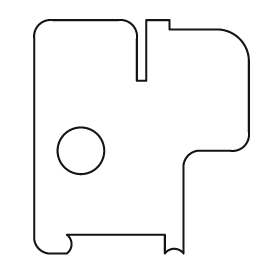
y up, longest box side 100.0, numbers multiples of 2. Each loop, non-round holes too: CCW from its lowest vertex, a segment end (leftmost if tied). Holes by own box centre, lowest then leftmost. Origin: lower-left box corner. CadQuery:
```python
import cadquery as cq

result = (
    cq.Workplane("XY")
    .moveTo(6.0, 0.0)
    .lineTo(14.0, 0.0)
    .threePointArc((16.0, 4.0), (14.0, 8.0))
    .lineTo(56.0, 8.0)
    .lineTo(56.0, 0.0)
    .threePointArc((60.0, 2.0), (64.0, 0.0))
    .lineTo(64.0, 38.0)
    .threePointArc((66.0, 42.0), (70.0, 44.0))
    .lineTo(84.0, 44.0)
    .threePointArc((90.0, 46.0), (92.0, 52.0))
    .lineTo(92.0, 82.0)
    .threePointArc((88.0, 92.0), (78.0, 96.0))
    .lineTo(58.0, 96.0)
    .lineTo(58.0, 100.0)
    .lineTo(48.0, 100.0)
    .lineTo(48.0, 74.0)
    .lineTo(44.0, 74.0)
    .lineTo(44.0, 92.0)
    .threePointArc((42.0, 98.0), (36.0, 100.0))
    .lineTo(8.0, 100.0)
    .threePointArc((2.0, 98.0), (0.0, 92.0))
    .lineTo(0.0, 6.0)
    .threePointArc((2.0, 2.0), (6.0, 0.0))
    .close()
    .moveTo(20.0, 44.0)
    .circle(10.0)
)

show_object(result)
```